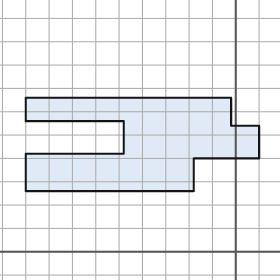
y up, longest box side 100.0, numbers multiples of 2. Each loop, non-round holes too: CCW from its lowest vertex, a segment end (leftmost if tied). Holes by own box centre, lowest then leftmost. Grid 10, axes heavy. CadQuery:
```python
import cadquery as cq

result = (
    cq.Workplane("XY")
    .moveTo(-90.0, 26.0)
    .lineTo(-18.0, 26.0)
    .lineTo(-18.0, 40.0)
    .lineTo(10.0, 40.0)
    .lineTo(10.0, 54.0)
    .lineTo(-2.0, 54.0)
    .lineTo(-2.0, 66.0)
    .lineTo(-90.0, 66.0)
    .lineTo(-90.0, 56.0)
    .lineTo(-48.0, 56.0)
    .lineTo(-48.0, 42.0)
    .lineTo(-90.0, 42.0)
    .close()
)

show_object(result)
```